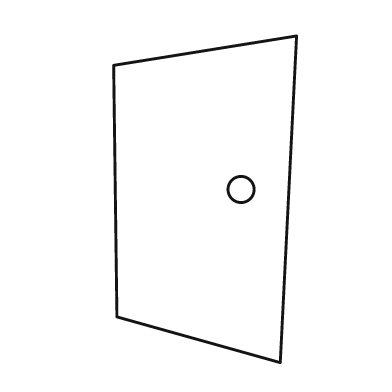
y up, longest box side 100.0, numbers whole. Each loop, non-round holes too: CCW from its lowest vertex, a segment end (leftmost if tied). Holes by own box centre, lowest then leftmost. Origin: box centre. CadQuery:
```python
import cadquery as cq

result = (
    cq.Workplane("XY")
    .moveTo(23.0, -50.0)
    .lineTo(28.0, 50.0)
    .lineTo(-28.0, 41.0)
    .lineTo(-27.0, -36.0)
    .close()
    .moveTo(11.0, 3.0)
    .circle(4.0)
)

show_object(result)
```